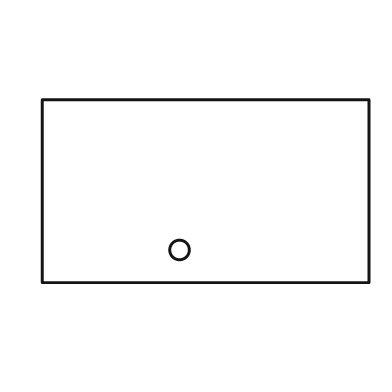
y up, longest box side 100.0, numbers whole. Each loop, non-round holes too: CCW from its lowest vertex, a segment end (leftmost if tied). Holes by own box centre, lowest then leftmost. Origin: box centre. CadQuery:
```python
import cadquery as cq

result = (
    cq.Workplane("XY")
    .moveTo(-50.0, -28.0)
    .lineTo(50.0, -28.0)
    .lineTo(50.0, 28.0)
    .lineTo(-50.0, 28.0)
    .close()
    .moveTo(-8.0, -18.0)
    .circle(3.0)
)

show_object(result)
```